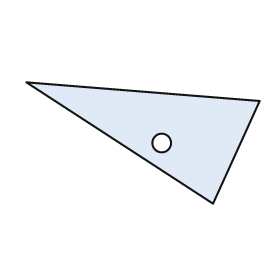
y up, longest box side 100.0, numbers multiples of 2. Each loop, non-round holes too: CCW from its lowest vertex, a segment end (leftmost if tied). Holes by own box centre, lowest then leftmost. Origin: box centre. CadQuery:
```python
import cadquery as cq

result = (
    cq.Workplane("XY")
    .moveTo(30.0, -26.0)
    .lineTo(50.0, 18.0)
    .lineTo(-50.0, 26.0)
    .close()
    .moveTo(8.0, 0.0)
    .circle(4.0)
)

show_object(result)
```